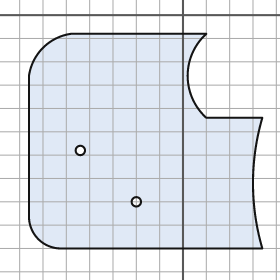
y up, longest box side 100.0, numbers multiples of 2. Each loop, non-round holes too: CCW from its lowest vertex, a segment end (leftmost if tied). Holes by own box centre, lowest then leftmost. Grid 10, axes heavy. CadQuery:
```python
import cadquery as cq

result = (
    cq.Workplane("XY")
    .moveTo(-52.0, -100.0)
    .lineTo(34.0, -100.0)
    .threePointArc((30.0, -72.0), (34.0, -44.0))
    .lineTo(10.0, -44.0)
    .threePointArc((2.0, -26.0), (10.0, -8.0))
    .lineTo(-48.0, -8.0)
    .threePointArc((-60.0, -14.0), (-66.0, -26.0))
    .lineTo(-66.0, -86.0)
    .threePointArc((-62.0, -96.0), (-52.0, -100.0))
    .close()
    .moveTo(-20.0, -80.0)
    .circle(2.0)
    .moveTo(-44.0, -58.0)
    .circle(2.0)
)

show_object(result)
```